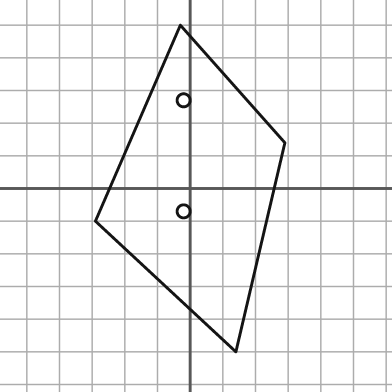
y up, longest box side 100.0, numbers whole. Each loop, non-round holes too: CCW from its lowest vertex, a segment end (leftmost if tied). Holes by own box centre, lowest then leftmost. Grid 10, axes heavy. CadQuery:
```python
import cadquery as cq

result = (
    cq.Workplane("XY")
    .moveTo(14.0, -50.0)
    .lineTo(29.0, 14.0)
    .lineTo(-3.0, 50.0)
    .lineTo(-29.0, -10.0)
    .close()
    .moveTo(-2.0, -7.0)
    .circle(2.0)
    .moveTo(-2.0, 27.0)
    .circle(2.0)
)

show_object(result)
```